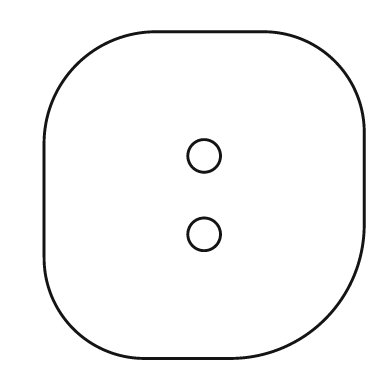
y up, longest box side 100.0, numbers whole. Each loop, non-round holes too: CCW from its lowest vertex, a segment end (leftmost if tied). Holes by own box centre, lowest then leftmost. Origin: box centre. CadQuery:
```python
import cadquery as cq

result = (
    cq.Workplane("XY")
    .moveTo(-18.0, -50.0)
    .lineTo(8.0, -50.0)
    .threePointArc((37.0, -38.0), (49.0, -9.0))
    .lineTo(49.0, 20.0)
    .threePointArc((40.0, 41.0), (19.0, 50.0))
    .lineTo(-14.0, 50.0)
    .threePointArc((-39.0, 40.0), (-49.0, 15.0))
    .lineTo(-49.0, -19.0)
    .threePointArc((-40.0, -41.0), (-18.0, -50.0))
    .close()
    .moveTo(0.0, -12.0)
    .circle(5.0)
    .moveTo(0.0, 12.0)
    .circle(5.0)
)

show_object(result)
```